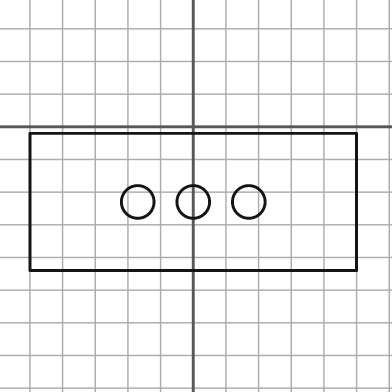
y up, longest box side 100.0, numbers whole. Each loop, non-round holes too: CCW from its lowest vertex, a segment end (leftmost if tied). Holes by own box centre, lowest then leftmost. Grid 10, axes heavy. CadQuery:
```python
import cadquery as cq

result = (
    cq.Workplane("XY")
    .moveTo(-50.0, -44.0)
    .lineTo(50.0, -44.0)
    .lineTo(50.0, -2.0)
    .lineTo(-50.0, -2.0)
    .close()
    .moveTo(-17.0, -23.0)
    .circle(5.0)
    .moveTo(0.0, -23.0)
    .circle(5.0)
    .moveTo(17.0, -23.0)
    .circle(5.0)
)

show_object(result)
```